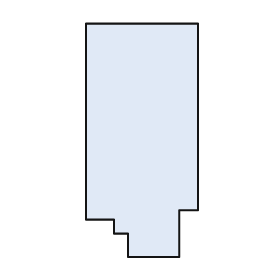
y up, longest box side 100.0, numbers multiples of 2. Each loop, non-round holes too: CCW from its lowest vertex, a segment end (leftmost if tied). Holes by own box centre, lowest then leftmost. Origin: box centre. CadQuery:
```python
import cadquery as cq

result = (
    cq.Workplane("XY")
    .moveTo(-6.0, -50.0)
    .lineTo(16.0, -50.0)
    .lineTo(16.0, -30.0)
    .lineTo(24.0, -30.0)
    .lineTo(24.0, 50.0)
    .lineTo(-24.0, 50.0)
    .lineTo(-24.0, -34.0)
    .lineTo(-12.0, -34.0)
    .lineTo(-12.0, -40.0)
    .lineTo(-6.0, -40.0)
    .close()
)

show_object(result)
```